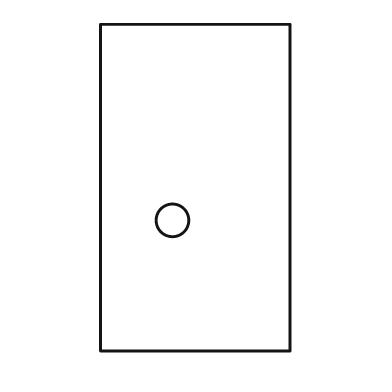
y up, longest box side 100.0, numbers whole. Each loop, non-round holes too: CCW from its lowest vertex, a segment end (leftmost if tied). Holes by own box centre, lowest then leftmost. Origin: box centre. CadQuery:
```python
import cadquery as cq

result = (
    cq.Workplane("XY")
    .moveTo(-29.0, -50.0)
    .lineTo(29.0, -50.0)
    .lineTo(29.0, 50.0)
    .lineTo(-29.0, 50.0)
    .close()
    .moveTo(-7.0, -10.0)
    .circle(5.0)
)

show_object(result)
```